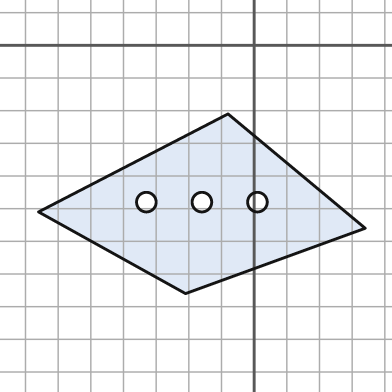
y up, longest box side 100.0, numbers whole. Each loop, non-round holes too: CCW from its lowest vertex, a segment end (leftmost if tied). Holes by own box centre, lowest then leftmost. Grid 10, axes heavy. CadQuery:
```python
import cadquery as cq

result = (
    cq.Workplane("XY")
    .moveTo(-21.0, -76.0)
    .lineTo(34.0, -56.0)
    .lineTo(-8.0, -21.0)
    .lineTo(-66.0, -51.0)
    .close()
    .moveTo(-33.0, -48.0)
    .circle(3.0)
    .moveTo(-16.0, -48.0)
    .circle(3.0)
    .moveTo(1.0, -48.0)
    .circle(3.0)
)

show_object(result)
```